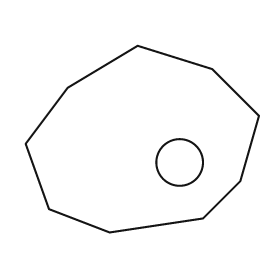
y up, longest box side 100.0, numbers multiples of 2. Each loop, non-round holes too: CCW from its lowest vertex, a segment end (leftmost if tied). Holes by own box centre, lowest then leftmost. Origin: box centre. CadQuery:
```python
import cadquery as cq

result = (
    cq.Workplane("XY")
    .moveTo(-14.0, -40.0)
    .lineTo(26.0, -34.0)
    .lineTo(42.0, -18.0)
    .lineTo(50.0, 10.0)
    .lineTo(30.0, 30.0)
    .lineTo(-2.0, 40.0)
    .lineTo(-32.0, 22.0)
    .lineTo(-50.0, -2.0)
    .lineTo(-40.0, -30.0)
    .close()
    .moveTo(16.0, -10.0)
    .circle(10.0)
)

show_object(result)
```